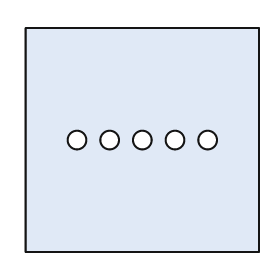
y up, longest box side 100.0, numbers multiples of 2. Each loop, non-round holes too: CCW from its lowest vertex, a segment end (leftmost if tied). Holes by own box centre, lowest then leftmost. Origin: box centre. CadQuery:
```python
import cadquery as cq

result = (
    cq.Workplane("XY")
    .moveTo(-50.0, -48.0)
    .lineTo(50.0, -48.0)
    .lineTo(50.0, 48.0)
    .lineTo(-50.0, 48.0)
    .close()
    .moveTo(-28.0, 0.0)
    .circle(4.0)
    .moveTo(-14.0, 0.0)
    .circle(4.0)
    .moveTo(0.0, 0.0)
    .circle(4.0)
    .moveTo(14.0, 0.0)
    .circle(4.0)
    .moveTo(28.0, 0.0)
    .circle(4.0)
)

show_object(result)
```